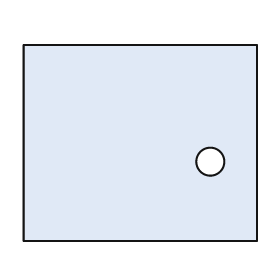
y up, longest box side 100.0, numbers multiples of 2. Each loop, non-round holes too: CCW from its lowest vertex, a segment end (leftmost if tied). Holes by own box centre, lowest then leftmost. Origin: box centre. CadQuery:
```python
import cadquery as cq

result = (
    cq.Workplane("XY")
    .moveTo(-50.0, -42.0)
    .lineTo(50.0, -42.0)
    .lineTo(50.0, 42.0)
    .lineTo(-50.0, 42.0)
    .close()
    .moveTo(30.0, -8.0)
    .circle(6.0)
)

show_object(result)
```